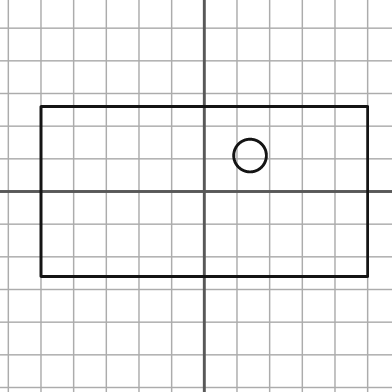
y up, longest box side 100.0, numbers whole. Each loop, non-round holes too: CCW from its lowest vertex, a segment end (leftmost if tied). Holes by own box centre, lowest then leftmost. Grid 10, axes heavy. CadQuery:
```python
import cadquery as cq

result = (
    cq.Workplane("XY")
    .moveTo(-50.0, -26.0)
    .lineTo(50.0, -26.0)
    .lineTo(50.0, 26.0)
    .lineTo(-50.0, 26.0)
    .close()
    .moveTo(14.0, 11.0)
    .circle(5.0)
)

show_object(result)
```